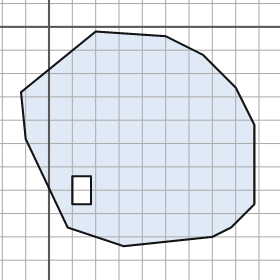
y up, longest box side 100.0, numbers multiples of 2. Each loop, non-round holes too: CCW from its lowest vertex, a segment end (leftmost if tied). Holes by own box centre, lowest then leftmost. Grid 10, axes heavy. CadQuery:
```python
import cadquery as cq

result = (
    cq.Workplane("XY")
    .moveTo(32.0, -94.0)
    .lineTo(70.0, -90.0)
    .lineTo(78.0, -86.0)
    .lineTo(88.0, -76.0)
    .lineTo(88.0, -42.0)
    .lineTo(80.0, -26.0)
    .lineTo(66.0, -12.0)
    .lineTo(50.0, -4.0)
    .lineTo(20.0, -2.0)
    .lineTo(-12.0, -28.0)
    .lineTo(-10.0, -48.0)
    .lineTo(8.0, -86.0)
    .close()
    .moveTo(10.0, -76.0)
    .lineTo(18.0, -76.0)
    .lineTo(18.0, -64.0)
    .lineTo(10.0, -64.0)
    .close()
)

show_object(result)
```